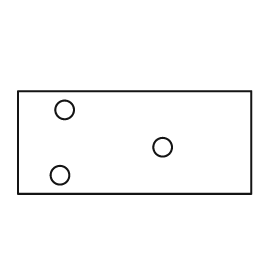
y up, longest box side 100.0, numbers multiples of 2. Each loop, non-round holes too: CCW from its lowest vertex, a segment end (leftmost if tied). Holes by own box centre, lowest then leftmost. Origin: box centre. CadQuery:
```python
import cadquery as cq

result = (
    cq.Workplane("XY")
    .moveTo(-50.0, -22.0)
    .lineTo(50.0, -22.0)
    .lineTo(50.0, 22.0)
    .lineTo(-50.0, 22.0)
    .close()
    .moveTo(-32.0, -14.0)
    .circle(4.0)
    .moveTo(12.0, -2.0)
    .circle(4.0)
    .moveTo(-30.0, 14.0)
    .circle(4.0)
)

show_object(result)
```